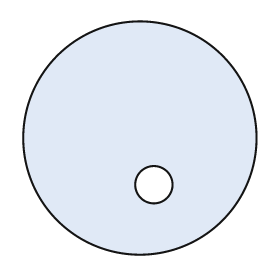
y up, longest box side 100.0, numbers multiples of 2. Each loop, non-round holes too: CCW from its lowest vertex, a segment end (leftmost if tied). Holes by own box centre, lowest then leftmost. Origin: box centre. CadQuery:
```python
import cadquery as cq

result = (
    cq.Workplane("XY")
    .moveTo(0.0, 0.0)
    .circle(50.0)
    .moveTo(6.0, -20.0)
    .circle(8.0)
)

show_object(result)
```